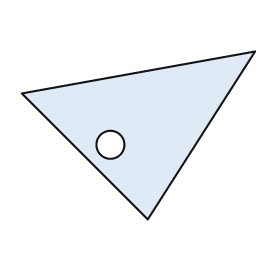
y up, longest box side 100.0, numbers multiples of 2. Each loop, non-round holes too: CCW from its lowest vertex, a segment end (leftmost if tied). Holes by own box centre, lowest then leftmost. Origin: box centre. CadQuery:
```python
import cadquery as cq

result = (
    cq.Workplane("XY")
    .moveTo(4.0, -36.0)
    .lineTo(50.0, 36.0)
    .lineTo(-50.0, 18.0)
    .close()
    .moveTo(-12.0, -4.0)
    .circle(6.0)
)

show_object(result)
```